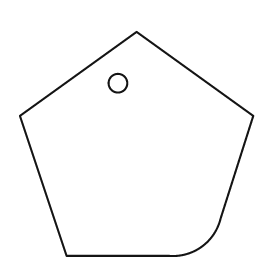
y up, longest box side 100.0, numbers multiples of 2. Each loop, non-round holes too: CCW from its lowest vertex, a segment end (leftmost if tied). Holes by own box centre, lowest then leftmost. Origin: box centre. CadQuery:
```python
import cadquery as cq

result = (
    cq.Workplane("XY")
    .moveTo(-30.0, -48.0)
    .lineTo(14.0, -48.0)
    .threePointArc((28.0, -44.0), (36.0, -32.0))
    .lineTo(50.0, 12.0)
    .lineTo(0.0, 48.0)
    .lineTo(-50.0, 12.0)
    .close()
    .moveTo(-8.0, 26.0)
    .circle(4.0)
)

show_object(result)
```